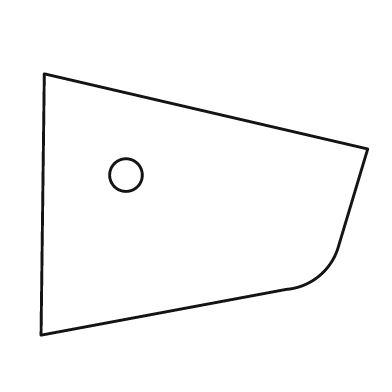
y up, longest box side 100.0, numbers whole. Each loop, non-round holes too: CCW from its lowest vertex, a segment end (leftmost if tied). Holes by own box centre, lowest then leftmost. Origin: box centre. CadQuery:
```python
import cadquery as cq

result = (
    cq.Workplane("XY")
    .moveTo(-50.0, -40.0)
    .lineTo(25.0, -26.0)
    .threePointArc((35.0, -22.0), (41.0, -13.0))
    .lineTo(50.0, 17.0)
    .lineTo(-49.0, 40.0)
    .close()
    .moveTo(-24.0, 9.0)
    .circle(5.0)
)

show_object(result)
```